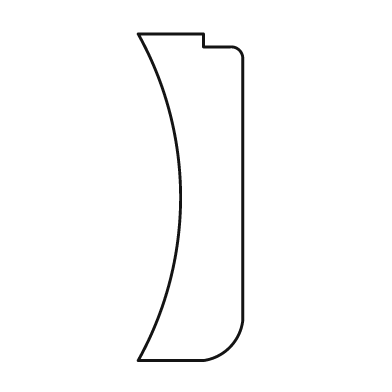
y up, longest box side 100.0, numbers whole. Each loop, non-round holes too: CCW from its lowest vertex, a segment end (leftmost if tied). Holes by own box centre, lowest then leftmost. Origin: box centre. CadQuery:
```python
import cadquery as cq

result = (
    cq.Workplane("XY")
    .moveTo(-16.0, -50.0)
    .lineTo(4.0, -50.0)
    .threePointArc((12.0, -46.0), (16.0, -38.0))
    .lineTo(16.0, 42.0)
    .threePointArc((15.0, 45.0), (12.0, 46.0))
    .lineTo(4.0, 46.0)
    .lineTo(4.0, 50.0)
    .lineTo(-16.0, 50.0)
    .threePointArc((-3.0, 0.0), (-16.0, -50.0))
    .close()
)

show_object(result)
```